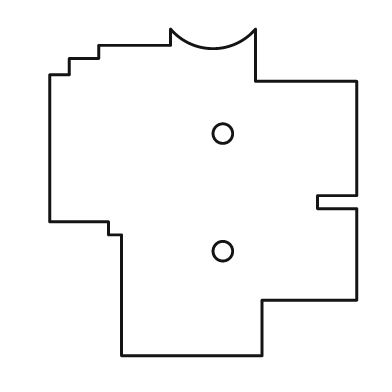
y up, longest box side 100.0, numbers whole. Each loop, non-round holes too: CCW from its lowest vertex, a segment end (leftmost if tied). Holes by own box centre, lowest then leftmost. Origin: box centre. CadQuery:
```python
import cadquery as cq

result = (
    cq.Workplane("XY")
    .moveTo(-25.0, -50.0)
    .lineTo(18.0, -50.0)
    .lineTo(18.0, -33.0)
    .lineTo(47.0, -33.0)
    .lineTo(47.0, -5.0)
    .lineTo(35.0, -5.0)
    .lineTo(35.0, -1.0)
    .lineTo(47.0, -1.0)
    .lineTo(47.0, 34.0)
    .lineTo(16.0, 34.0)
    .lineTo(16.0, 50.0)
    .threePointArc((3.0, 44.0), (-10.0, 50.0))
    .lineTo(-10.0, 45.0)
    .lineTo(-32.0, 45.0)
    .lineTo(-32.0, 41.0)
    .lineTo(-41.0, 41.0)
    .lineTo(-41.0, 36.0)
    .lineTo(-47.0, 36.0)
    .lineTo(-47.0, -9.0)
    .lineTo(-29.0, -9.0)
    .lineTo(-29.0, -13.0)
    .lineTo(-25.0, -13.0)
    .close()
    .moveTo(6.0, -18.0)
    .circle(3.0)
    .moveTo(6.0, 18.0)
    .circle(3.0)
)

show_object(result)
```